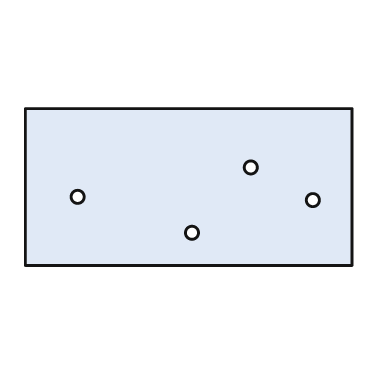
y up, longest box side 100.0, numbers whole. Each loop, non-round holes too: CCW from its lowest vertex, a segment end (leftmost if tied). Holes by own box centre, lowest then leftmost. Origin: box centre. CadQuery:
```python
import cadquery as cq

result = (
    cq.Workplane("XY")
    .moveTo(-50.0, -24.0)
    .lineTo(50.0, -24.0)
    .lineTo(50.0, 24.0)
    .lineTo(-50.0, 24.0)
    .close()
    .moveTo(1.0, -14.0)
    .circle(2.0)
    .moveTo(38.0, -4.0)
    .circle(2.0)
    .moveTo(-34.0, -3.0)
    .circle(2.0)
    .moveTo(19.0, 6.0)
    .circle(2.0)
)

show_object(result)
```